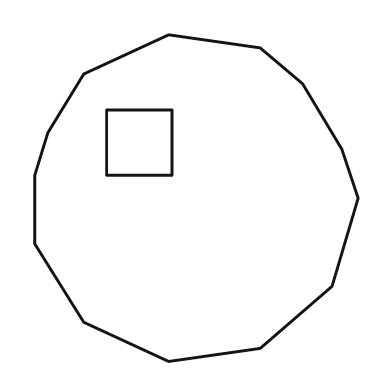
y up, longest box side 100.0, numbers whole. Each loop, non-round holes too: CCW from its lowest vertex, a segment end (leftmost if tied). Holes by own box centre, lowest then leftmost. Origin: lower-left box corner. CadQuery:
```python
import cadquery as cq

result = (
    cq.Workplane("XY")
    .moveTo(41.0, 0.0)
    .lineTo(69.0, 4.0)
    .lineTo(91.0, 23.0)
    .lineTo(99.0, 50.0)
    .lineTo(94.0, 65.0)
    .lineTo(82.0, 85.0)
    .lineTo(69.0, 96.0)
    .lineTo(41.0, 100.0)
    .lineTo(15.0, 88.0)
    .lineTo(4.0, 70.0)
    .lineTo(0.0, 57.0)
    .lineTo(0.0, 36.0)
    .lineTo(15.0, 12.0)
    .close()
    .moveTo(22.0, 57.0)
    .lineTo(42.0, 57.0)
    .lineTo(42.0, 77.0)
    .lineTo(22.0, 77.0)
    .close()
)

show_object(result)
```